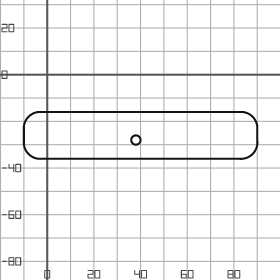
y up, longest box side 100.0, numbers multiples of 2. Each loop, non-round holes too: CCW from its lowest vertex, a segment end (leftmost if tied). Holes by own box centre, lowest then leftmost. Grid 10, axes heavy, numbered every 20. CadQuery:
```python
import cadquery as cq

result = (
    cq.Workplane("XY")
    .moveTo(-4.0, -36.0)
    .lineTo(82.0, -36.0)
    .threePointArc((88.0, -34.0), (90.0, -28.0))
    .lineTo(90.0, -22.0)
    .threePointArc((88.0, -18.0), (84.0, -16.0))
    .lineTo(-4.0, -16.0)
    .threePointArc((-8.0, -18.0), (-10.0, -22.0))
    .lineTo(-10.0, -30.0)
    .threePointArc((-8.0, -34.0), (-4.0, -36.0))
    .close()
    .moveTo(38.0, -28.0)
    .circle(2.0)
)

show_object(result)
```